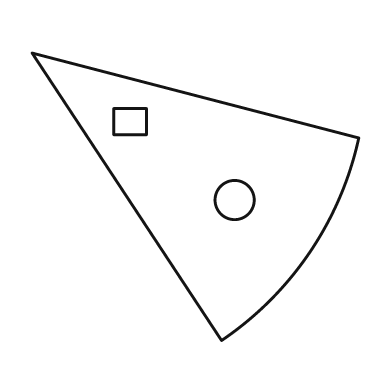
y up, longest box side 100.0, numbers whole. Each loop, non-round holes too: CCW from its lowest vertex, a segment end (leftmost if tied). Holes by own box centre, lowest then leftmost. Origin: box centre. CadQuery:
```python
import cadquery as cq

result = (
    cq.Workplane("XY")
    .moveTo(8.0, -44.0)
    .threePointArc((35.0, -17.0), (50.0, 18.0))
    .lineTo(-50.0, 44.0)
    .close()
    .moveTo(12.0, -1.0)
    .circle(6.0)
    .moveTo(-25.0, 19.0)
    .lineTo(-15.0, 19.0)
    .lineTo(-15.0, 27.0)
    .lineTo(-25.0, 27.0)
    .close()
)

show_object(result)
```